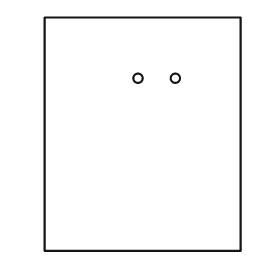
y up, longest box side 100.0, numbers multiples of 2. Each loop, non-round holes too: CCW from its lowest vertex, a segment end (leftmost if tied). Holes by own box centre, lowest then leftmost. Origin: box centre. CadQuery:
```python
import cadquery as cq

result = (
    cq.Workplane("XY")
    .moveTo(-42.0, -50.0)
    .lineTo(42.0, -50.0)
    .lineTo(42.0, 50.0)
    .lineTo(-42.0, 50.0)
    .close()
    .moveTo(-2.0, 24.0)
    .circle(2.0)
    .moveTo(14.0, 24.0)
    .circle(2.0)
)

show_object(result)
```